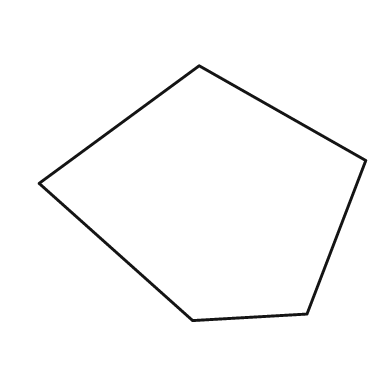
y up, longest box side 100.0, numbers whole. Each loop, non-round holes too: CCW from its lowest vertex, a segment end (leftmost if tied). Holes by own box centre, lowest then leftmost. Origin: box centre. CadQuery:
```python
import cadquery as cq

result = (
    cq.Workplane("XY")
    .moveTo(-3.0, -39.0)
    .lineTo(32.0, -37.0)
    .lineTo(50.0, 10.0)
    .lineTo(-1.0, 39.0)
    .lineTo(-50.0, 3.0)
    .close()
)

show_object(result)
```